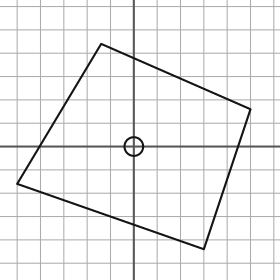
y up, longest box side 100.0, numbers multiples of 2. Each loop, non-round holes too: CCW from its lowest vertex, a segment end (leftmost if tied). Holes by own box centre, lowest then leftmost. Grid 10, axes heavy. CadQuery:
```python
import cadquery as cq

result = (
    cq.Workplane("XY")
    .moveTo(30.0, -44.0)
    .lineTo(50.0, 16.0)
    .lineTo(-14.0, 44.0)
    .lineTo(-50.0, -16.0)
    .close()
    .moveTo(0.0, 0.0)
    .circle(4.0)
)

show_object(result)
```